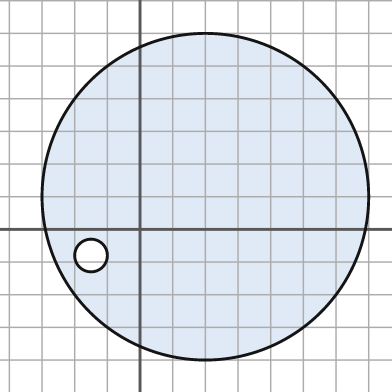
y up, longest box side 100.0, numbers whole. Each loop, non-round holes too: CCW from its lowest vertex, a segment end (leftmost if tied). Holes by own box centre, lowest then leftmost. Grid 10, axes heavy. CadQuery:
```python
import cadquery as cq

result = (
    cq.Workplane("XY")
    .moveTo(20.0, 10.0)
    .circle(50.0)
    .moveTo(-15.0, -8.0)
    .circle(5.0)
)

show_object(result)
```